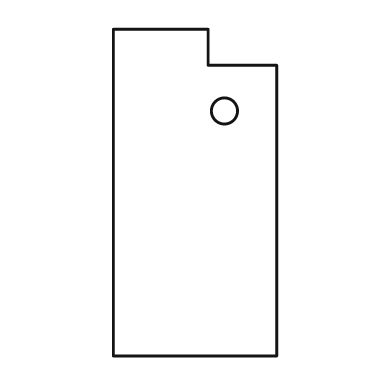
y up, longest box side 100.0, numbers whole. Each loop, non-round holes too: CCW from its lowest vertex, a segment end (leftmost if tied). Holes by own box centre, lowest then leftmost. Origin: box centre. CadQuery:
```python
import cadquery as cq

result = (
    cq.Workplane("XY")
    .moveTo(-25.0, -50.0)
    .lineTo(25.0, -50.0)
    .lineTo(25.0, 39.0)
    .lineTo(4.0, 39.0)
    .lineTo(4.0, 50.0)
    .lineTo(-25.0, 50.0)
    .close()
    .moveTo(9.0, 25.0)
    .circle(4.0)
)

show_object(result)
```